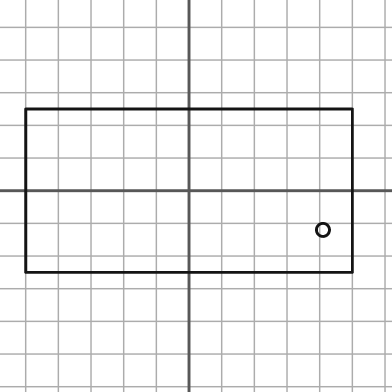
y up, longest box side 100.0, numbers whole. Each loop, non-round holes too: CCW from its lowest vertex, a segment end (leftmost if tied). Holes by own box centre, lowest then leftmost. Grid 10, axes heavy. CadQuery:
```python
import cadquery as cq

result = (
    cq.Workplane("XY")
    .moveTo(-50.0, -25.0)
    .lineTo(50.0, -25.0)
    .lineTo(50.0, 25.0)
    .lineTo(-50.0, 25.0)
    .close()
    .moveTo(41.0, -12.0)
    .circle(2.0)
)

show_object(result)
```